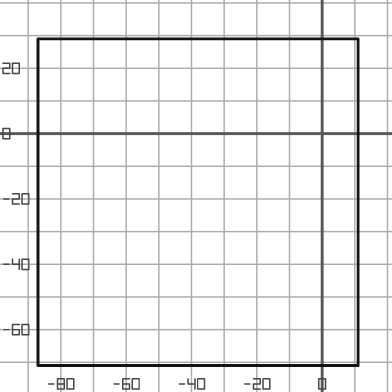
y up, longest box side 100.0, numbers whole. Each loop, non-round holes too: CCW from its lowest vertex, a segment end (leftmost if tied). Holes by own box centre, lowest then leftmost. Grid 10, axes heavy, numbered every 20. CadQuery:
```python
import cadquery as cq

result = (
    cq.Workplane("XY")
    .moveTo(-87.0, -71.0)
    .lineTo(11.0, -71.0)
    .lineTo(11.0, 29.0)
    .lineTo(-87.0, 29.0)
    .close()
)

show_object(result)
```